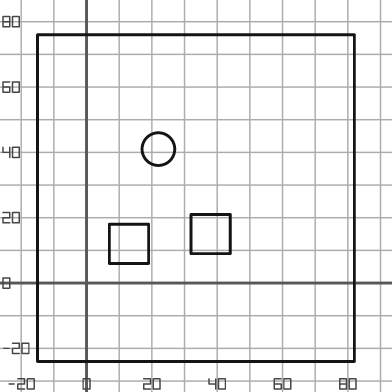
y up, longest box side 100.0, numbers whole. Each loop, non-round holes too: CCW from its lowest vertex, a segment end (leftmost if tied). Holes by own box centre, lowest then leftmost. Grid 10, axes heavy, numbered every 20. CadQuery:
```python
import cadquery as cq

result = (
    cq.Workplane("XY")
    .moveTo(-15.0, -24.0)
    .lineTo(82.0, -24.0)
    .lineTo(82.0, 76.0)
    .lineTo(-15.0, 76.0)
    .close()
    .moveTo(7.0, 6.0)
    .lineTo(19.0, 6.0)
    .lineTo(19.0, 18.0)
    .lineTo(7.0, 18.0)
    .close()
    .moveTo(32.0, 9.0)
    .lineTo(44.0, 9.0)
    .lineTo(44.0, 21.0)
    .lineTo(32.0, 21.0)
    .close()
    .moveTo(22.0, 41.0)
    .circle(5.0)
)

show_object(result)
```